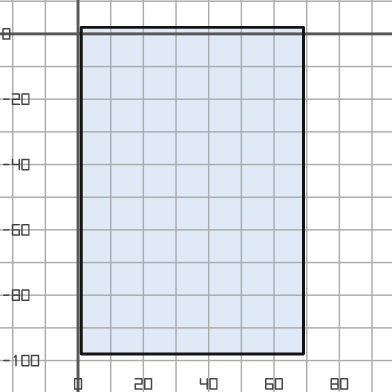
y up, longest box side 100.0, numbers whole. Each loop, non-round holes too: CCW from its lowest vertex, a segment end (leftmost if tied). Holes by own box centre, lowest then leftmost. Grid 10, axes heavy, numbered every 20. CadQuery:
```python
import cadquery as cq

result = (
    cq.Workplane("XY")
    .moveTo(1.0, -98.0)
    .lineTo(69.0, -98.0)
    .lineTo(69.0, 2.0)
    .lineTo(1.0, 2.0)
    .close()
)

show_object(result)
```